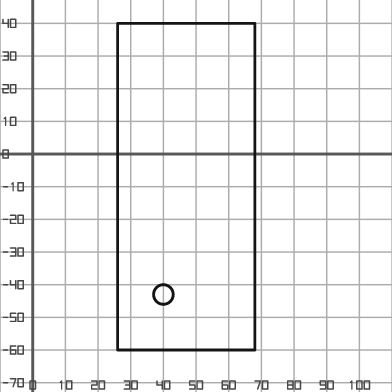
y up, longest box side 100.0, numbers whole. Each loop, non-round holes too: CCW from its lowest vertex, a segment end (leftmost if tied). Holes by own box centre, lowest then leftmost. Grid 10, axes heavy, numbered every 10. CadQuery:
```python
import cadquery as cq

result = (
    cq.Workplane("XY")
    .moveTo(26.0, -60.0)
    .lineTo(68.0, -60.0)
    .lineTo(68.0, 40.0)
    .lineTo(26.0, 40.0)
    .close()
    .moveTo(40.0, -43.0)
    .circle(3.0)
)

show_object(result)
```